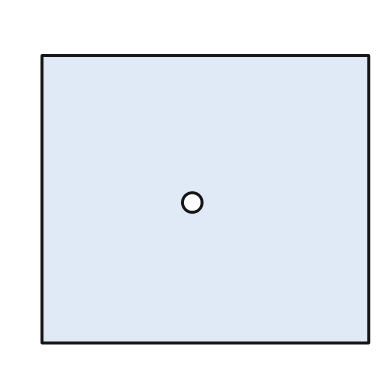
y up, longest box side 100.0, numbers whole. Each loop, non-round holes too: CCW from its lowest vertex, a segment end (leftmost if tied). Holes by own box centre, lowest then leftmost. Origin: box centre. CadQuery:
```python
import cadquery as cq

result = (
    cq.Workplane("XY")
    .moveTo(-50.0, -44.0)
    .lineTo(50.0, -44.0)
    .lineTo(50.0, 44.0)
    .lineTo(-50.0, 44.0)
    .close()
    .moveTo(-4.0, -1.0)
    .circle(3.0)
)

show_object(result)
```